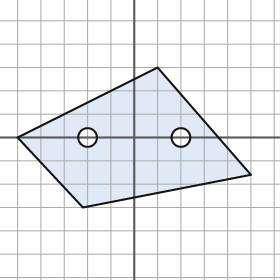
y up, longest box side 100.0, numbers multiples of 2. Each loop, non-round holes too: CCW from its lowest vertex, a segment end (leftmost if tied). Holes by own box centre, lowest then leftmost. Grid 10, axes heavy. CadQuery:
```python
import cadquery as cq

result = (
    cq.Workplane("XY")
    .moveTo(-22.0, -30.0)
    .lineTo(50.0, -16.0)
    .lineTo(10.0, 30.0)
    .lineTo(-50.0, 0.0)
    .close()
    .moveTo(-20.0, 0.0)
    .circle(4.0)
    .moveTo(20.0, 0.0)
    .circle(4.0)
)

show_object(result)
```